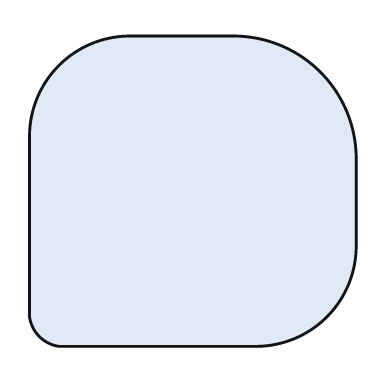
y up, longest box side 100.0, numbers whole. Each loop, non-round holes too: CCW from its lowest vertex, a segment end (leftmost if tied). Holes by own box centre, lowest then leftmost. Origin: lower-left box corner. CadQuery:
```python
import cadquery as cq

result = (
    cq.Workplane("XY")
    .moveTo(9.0, 0.0)
    .lineTo(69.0, 0.0)
    .threePointArc((91.0, 9.0), (100.0, 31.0))
    .lineTo(100.0, 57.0)
    .threePointArc((89.0, 84.0), (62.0, 95.0))
    .lineTo(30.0, 95.0)
    .threePointArc((9.0, 86.0), (0.0, 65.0))
    .lineTo(0.0, 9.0)
    .threePointArc((3.0, 3.0), (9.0, 0.0))
    .close()
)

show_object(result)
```